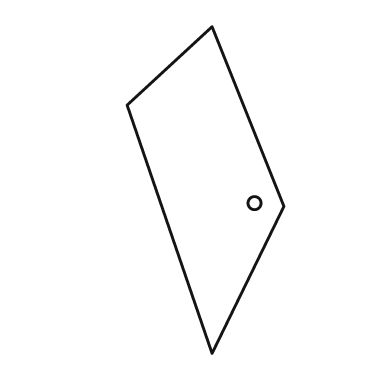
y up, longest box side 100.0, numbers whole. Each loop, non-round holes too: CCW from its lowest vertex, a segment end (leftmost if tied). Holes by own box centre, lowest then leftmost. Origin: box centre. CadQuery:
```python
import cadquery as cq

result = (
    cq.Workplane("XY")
    .moveTo(2.0, -50.0)
    .lineTo(24.0, -5.0)
    .lineTo(2.0, 50.0)
    .lineTo(-24.0, 26.0)
    .close()
    .moveTo(15.0, -4.0)
    .circle(2.0)
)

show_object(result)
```